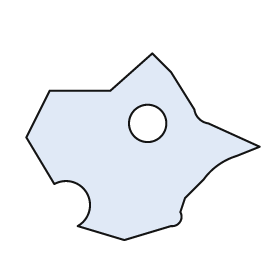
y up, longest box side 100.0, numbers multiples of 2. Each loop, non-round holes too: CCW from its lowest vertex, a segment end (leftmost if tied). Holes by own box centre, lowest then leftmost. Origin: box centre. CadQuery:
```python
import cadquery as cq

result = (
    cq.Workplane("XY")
    .moveTo(-8.0, -40.0)
    .lineTo(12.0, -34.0)
    .threePointArc((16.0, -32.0), (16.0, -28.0))
    .lineTo(18.0, -22.0)
    .lineTo(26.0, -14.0)
    .threePointArc((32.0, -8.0), (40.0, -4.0))
    .lineTo(50.0, 0.0)
    .lineTo(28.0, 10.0)
    .threePointArc((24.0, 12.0), (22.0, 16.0))
    .lineTo(12.0, 32.0)
    .lineTo(4.0, 40.0)
    .lineTo(-14.0, 24.0)
    .lineTo(-40.0, 24.0)
    .lineTo(-50.0, 4.0)
    .lineTo(-38.0, -16.0)
    .threePointArc((-24.0, -20.0), (-28.0, -34.0))
    .close()
    .moveTo(2.0, 10.0)
    .circle(8.0)
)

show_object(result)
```